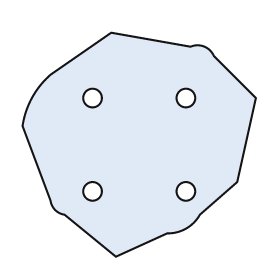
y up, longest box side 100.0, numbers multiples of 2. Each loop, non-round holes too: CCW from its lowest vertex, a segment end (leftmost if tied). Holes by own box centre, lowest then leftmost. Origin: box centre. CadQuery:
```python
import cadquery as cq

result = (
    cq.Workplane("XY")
    .moveTo(-10.0, -48.0)
    .lineTo(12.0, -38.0)
    .threePointArc((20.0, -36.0), (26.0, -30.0))
    .lineTo(42.0, -16.0)
    .lineTo(50.0, 20.0)
    .lineTo(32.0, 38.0)
    .threePointArc((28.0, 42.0), (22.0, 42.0))
    .lineTo(-12.0, 48.0)
    .lineTo(-38.0, 30.0)
    .threePointArc((-46.0, 20.0), (-50.0, 8.0))
    .lineTo(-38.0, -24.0)
    .threePointArc((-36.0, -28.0), (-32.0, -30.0))
    .close()
    .moveTo(-20.0, -20.0)
    .circle(4.0)
    .moveTo(20.0, -20.0)
    .circle(4.0)
    .moveTo(-20.0, 20.0)
    .circle(4.0)
    .moveTo(20.0, 20.0)
    .circle(4.0)
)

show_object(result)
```